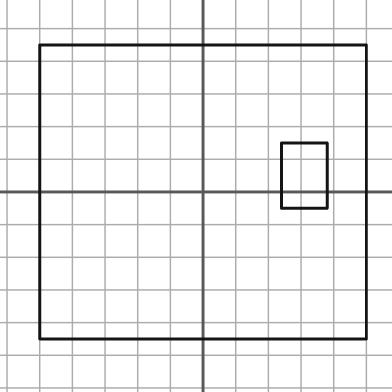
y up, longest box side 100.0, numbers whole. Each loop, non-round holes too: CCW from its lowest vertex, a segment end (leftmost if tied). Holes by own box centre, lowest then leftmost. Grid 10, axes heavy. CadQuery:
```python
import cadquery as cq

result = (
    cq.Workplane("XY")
    .moveTo(-50.0, -45.0)
    .lineTo(50.0, -45.0)
    .lineTo(50.0, 45.0)
    .lineTo(-50.0, 45.0)
    .close()
    .moveTo(24.0, -5.0)
    .lineTo(38.0, -5.0)
    .lineTo(38.0, 15.0)
    .lineTo(24.0, 15.0)
    .close()
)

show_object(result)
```